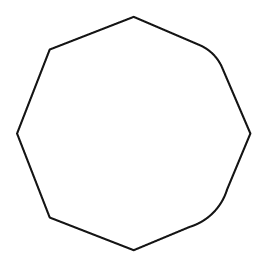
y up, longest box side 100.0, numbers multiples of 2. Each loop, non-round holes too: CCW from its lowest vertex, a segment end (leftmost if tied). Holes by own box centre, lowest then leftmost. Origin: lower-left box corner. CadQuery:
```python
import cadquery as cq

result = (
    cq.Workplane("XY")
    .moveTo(50.0, 0.0)
    .lineTo(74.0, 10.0)
    .threePointArc((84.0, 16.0), (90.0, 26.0))
    .lineTo(100.0, 50.0)
    .lineTo(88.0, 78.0)
    .threePointArc((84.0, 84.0), (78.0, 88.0))
    .lineTo(50.0, 100.0)
    .lineTo(14.0, 86.0)
    .lineTo(0.0, 50.0)
    .lineTo(14.0, 14.0)
    .close()
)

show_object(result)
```